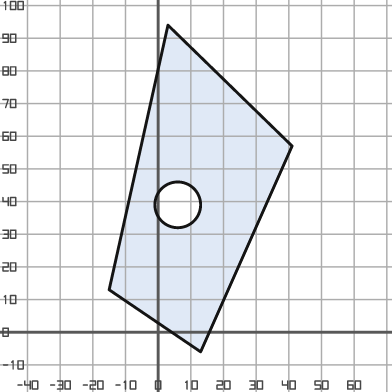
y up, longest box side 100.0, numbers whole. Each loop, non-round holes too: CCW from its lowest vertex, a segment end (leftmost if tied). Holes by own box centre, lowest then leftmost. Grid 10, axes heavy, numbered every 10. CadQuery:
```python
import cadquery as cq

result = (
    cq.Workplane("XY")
    .moveTo(13.0, -6.0)
    .lineTo(41.0, 57.0)
    .lineTo(3.0, 94.0)
    .lineTo(-15.0, 13.0)
    .close()
    .moveTo(6.0, 39.0)
    .circle(7.0)
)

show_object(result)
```